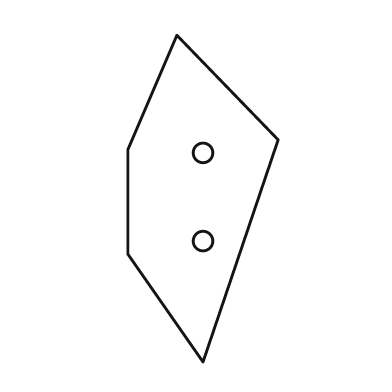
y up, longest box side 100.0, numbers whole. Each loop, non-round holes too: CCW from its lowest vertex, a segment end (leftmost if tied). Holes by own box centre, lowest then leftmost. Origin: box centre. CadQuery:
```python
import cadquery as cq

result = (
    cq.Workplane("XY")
    .moveTo(0.0, -50.0)
    .lineTo(23.0, 18.0)
    .lineTo(-8.0, 50.0)
    .lineTo(-23.0, 15.0)
    .lineTo(-23.0, -17.0)
    .close()
    .moveTo(0.0, -13.0)
    .circle(3.0)
    .moveTo(0.0, 14.0)
    .circle(3.0)
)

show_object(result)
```